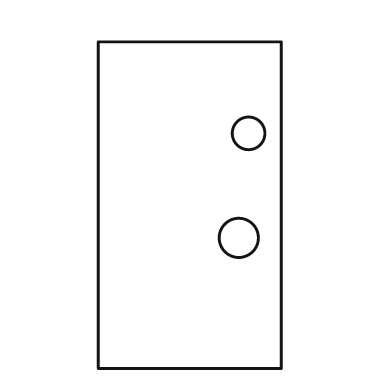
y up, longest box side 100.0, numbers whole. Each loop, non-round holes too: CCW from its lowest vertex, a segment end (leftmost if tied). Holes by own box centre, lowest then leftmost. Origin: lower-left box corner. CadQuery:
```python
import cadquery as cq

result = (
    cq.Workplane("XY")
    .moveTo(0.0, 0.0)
    .lineTo(56.0, 0.0)
    .lineTo(56.0, 100.0)
    .lineTo(0.0, 100.0)
    .close()
    .moveTo(43.0, 40.0)
    .circle(6.0)
    .moveTo(46.0, 72.0)
    .circle(5.0)
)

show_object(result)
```